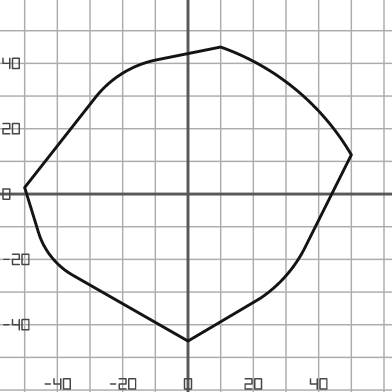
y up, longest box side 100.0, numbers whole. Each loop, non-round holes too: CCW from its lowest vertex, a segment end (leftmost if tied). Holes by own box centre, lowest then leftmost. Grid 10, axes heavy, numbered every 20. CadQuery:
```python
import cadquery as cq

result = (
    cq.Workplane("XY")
    .moveTo(0.0, -45.0)
    .lineTo(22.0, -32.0)
    .threePointArc((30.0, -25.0), (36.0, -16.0))
    .lineTo(50.0, 12.0)
    .threePointArc((33.0, 32.0), (10.0, 45.0))
    .lineTo(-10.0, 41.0)
    .threePointArc((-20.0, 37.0), (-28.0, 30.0))
    .lineTo(-50.0, 2.0)
    .lineTo(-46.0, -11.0)
    .threePointArc((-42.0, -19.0), (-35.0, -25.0))
    .close()
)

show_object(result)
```